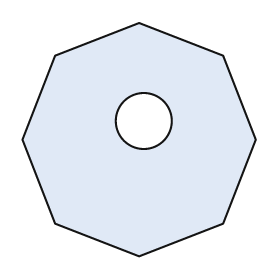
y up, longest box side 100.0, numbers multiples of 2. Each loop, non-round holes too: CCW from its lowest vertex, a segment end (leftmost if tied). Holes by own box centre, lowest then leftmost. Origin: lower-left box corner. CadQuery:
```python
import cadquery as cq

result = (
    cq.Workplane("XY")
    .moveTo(50.0, 0.0)
    .lineTo(86.0, 14.0)
    .lineTo(100.0, 50.0)
    .lineTo(86.0, 86.0)
    .lineTo(50.0, 100.0)
    .lineTo(14.0, 86.0)
    .lineTo(0.0, 50.0)
    .lineTo(14.0, 14.0)
    .close()
    .moveTo(52.0, 58.0)
    .circle(12.0)
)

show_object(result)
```